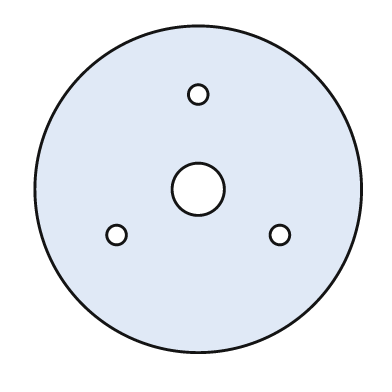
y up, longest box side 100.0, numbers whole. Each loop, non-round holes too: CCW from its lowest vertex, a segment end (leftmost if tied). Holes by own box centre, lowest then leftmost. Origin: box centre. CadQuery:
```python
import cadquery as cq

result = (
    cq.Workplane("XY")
    .moveTo(0.0, 0.0)
    .circle(50.0)
    .moveTo(-25.0, -14.0)
    .circle(3.0)
    .moveTo(25.0, -14.0)
    .circle(3.0)
    .moveTo(0.0, 0.0)
    .circle(8.0)
    .moveTo(0.0, 29.0)
    .circle(3.0)
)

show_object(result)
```